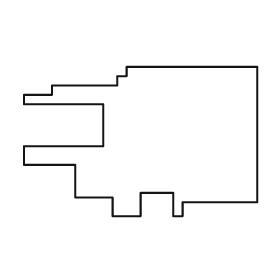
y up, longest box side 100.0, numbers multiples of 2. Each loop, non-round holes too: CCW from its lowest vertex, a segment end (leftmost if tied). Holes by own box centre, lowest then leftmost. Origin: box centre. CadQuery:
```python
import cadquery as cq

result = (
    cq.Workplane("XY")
    .moveTo(-12.0, -32.0)
    .lineTo(0.0, -32.0)
    .lineTo(0.0, -22.0)
    .lineTo(14.0, -22.0)
    .lineTo(14.0, -32.0)
    .lineTo(18.0, -32.0)
    .lineTo(18.0, -26.0)
    .lineTo(50.0, -26.0)
    .lineTo(50.0, 32.0)
    .lineTo(-6.0, 32.0)
    .lineTo(-6.0, 28.0)
    .lineTo(-10.0, 28.0)
    .lineTo(-10.0, 24.0)
    .lineTo(-38.0, 24.0)
    .lineTo(-38.0, 20.0)
    .lineTo(-50.0, 20.0)
    .lineTo(-50.0, 16.0)
    .lineTo(-16.0, 16.0)
    .lineTo(-16.0, -2.0)
    .lineTo(-50.0, -2.0)
    .lineTo(-50.0, -10.0)
    .lineTo(-28.0, -10.0)
    .lineTo(-28.0, -24.0)
    .lineTo(-12.0, -24.0)
    .close()
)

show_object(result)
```